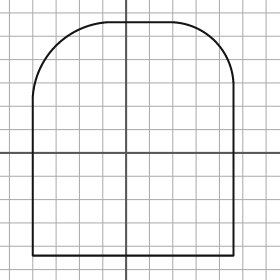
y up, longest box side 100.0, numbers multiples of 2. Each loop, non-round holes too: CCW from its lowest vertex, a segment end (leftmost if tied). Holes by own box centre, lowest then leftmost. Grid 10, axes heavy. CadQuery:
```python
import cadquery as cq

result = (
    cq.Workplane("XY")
    .moveTo(-40.0, -44.0)
    .lineTo(46.0, -44.0)
    .lineTo(46.0, 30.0)
    .threePointArc((38.0, 48.0), (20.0, 56.0))
    .lineTo(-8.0, 56.0)
    .threePointArc((-30.0, 46.0), (-40.0, 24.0))
    .close()
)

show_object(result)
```